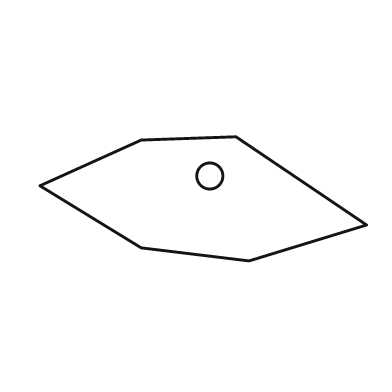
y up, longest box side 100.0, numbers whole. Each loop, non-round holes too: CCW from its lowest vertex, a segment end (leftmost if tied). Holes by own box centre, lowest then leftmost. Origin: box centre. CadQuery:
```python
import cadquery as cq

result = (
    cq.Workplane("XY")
    .moveTo(14.0, -19.0)
    .lineTo(50.0, -8.0)
    .lineTo(10.0, 19.0)
    .lineTo(-19.0, 18.0)
    .lineTo(-50.0, 4.0)
    .lineTo(-19.0, -15.0)
    .close()
    .moveTo(2.0, 7.0)
    .circle(4.0)
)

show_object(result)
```